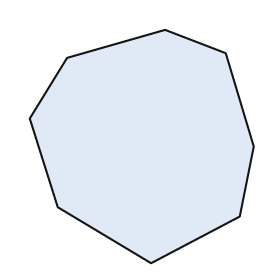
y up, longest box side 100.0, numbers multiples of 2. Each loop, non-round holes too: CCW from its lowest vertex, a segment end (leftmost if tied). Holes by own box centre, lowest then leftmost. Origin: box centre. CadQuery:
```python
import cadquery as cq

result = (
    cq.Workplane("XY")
    .moveTo(4.0, -50.0)
    .lineTo(42.0, -30.0)
    .lineTo(48.0, 0.0)
    .lineTo(36.0, 40.0)
    .lineTo(10.0, 50.0)
    .lineTo(-32.0, 38.0)
    .lineTo(-48.0, 12.0)
    .lineTo(-36.0, -26.0)
    .close()
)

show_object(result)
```